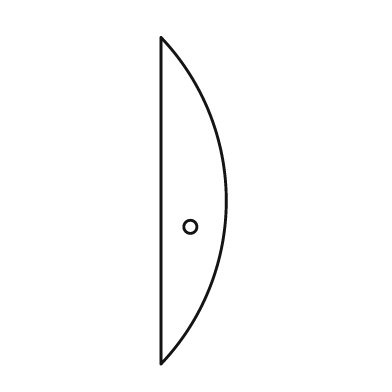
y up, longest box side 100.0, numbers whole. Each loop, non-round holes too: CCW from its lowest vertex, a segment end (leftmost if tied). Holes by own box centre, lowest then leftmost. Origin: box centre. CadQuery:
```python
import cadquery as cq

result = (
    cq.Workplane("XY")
    .moveTo(-10.0, -50.0)
    .threePointArc((10.0, 0.0), (-10.0, 50.0))
    .close()
    .moveTo(-1.0, -8.0)
    .circle(2.0)
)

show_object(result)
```